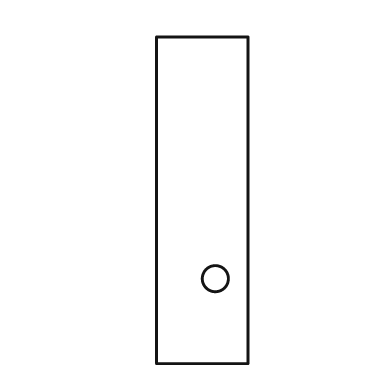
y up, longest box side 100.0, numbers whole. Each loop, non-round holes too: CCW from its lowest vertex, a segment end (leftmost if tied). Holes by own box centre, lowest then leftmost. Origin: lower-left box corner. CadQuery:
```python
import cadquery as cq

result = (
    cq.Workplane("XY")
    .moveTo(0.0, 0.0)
    .lineTo(28.0, 0.0)
    .lineTo(28.0, 100.0)
    .lineTo(0.0, 100.0)
    .close()
    .moveTo(18.0, 26.0)
    .circle(4.0)
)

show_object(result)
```